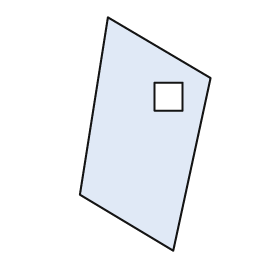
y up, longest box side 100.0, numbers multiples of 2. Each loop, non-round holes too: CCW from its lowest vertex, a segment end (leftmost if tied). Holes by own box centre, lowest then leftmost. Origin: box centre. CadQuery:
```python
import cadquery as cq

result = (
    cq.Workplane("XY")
    .moveTo(12.0, -50.0)
    .lineTo(28.0, 24.0)
    .lineTo(-16.0, 50.0)
    .lineTo(-28.0, -26.0)
    .close()
    .moveTo(4.0, 10.0)
    .lineTo(16.0, 10.0)
    .lineTo(16.0, 22.0)
    .lineTo(4.0, 22.0)
    .close()
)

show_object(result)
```